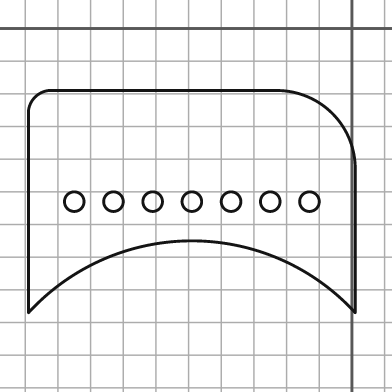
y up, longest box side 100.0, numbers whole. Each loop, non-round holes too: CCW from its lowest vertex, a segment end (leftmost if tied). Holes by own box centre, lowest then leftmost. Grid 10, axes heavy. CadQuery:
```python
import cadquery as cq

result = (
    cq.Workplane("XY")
    .moveTo(-99.0, -87.0)
    .threePointArc((-49.0, -65.0), (1.0, -87.0))
    .lineTo(1.0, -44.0)
    .threePointArc((-6.0, -26.0), (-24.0, -19.0))
    .lineTo(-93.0, -19.0)
    .threePointArc((-97.0, -21.0), (-99.0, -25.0))
    .close()
    .moveTo(-85.0, -53.0)
    .circle(3.0)
    .moveTo(-73.0, -53.0)
    .circle(3.0)
    .moveTo(-61.0, -53.0)
    .circle(3.0)
    .moveTo(-49.0, -53.0)
    .circle(3.0)
    .moveTo(-37.0, -53.0)
    .circle(3.0)
    .moveTo(-25.0, -53.0)
    .circle(3.0)
    .moveTo(-13.0, -53.0)
    .circle(3.0)
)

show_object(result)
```